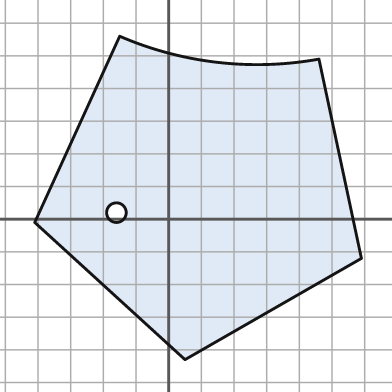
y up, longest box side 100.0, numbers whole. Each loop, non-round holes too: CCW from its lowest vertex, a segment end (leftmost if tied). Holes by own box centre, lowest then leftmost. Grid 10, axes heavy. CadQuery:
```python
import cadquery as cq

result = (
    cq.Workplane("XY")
    .moveTo(5.0, -43.0)
    .lineTo(59.0, -12.0)
    .lineTo(46.0, 49.0)
    .threePointArc((15.0, 48.0), (-15.0, 56.0))
    .lineTo(-41.0, -1.0)
    .close()
    .moveTo(-16.0, 2.0)
    .circle(3.0)
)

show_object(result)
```